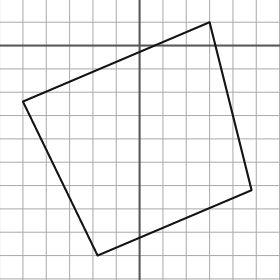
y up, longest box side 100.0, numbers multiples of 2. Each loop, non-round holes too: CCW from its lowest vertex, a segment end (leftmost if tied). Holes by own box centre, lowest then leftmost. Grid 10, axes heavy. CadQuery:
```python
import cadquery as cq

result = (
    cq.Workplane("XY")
    .moveTo(-18.0, -90.0)
    .lineTo(48.0, -62.0)
    .lineTo(30.0, 10.0)
    .lineTo(-50.0, -24.0)
    .close()
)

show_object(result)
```